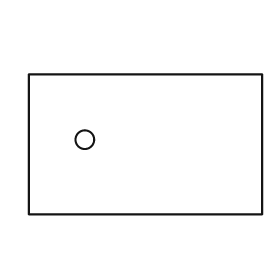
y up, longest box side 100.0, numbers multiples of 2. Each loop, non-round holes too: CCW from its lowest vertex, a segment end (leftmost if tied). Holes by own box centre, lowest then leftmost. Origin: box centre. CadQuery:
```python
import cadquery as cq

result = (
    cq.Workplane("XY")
    .moveTo(-50.0, -30.0)
    .lineTo(50.0, -30.0)
    .lineTo(50.0, 30.0)
    .lineTo(-50.0, 30.0)
    .close()
    .moveTo(-26.0, 2.0)
    .circle(4.0)
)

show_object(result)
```